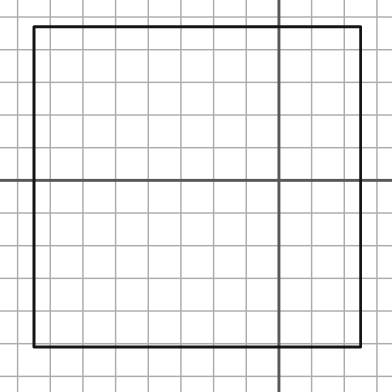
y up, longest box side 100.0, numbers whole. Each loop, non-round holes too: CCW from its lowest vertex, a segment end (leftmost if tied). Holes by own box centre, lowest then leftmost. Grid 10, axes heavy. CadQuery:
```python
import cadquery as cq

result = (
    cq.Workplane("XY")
    .moveTo(-75.0, -51.0)
    .lineTo(25.0, -51.0)
    .lineTo(25.0, 47.0)
    .lineTo(-75.0, 47.0)
    .close()
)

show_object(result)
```